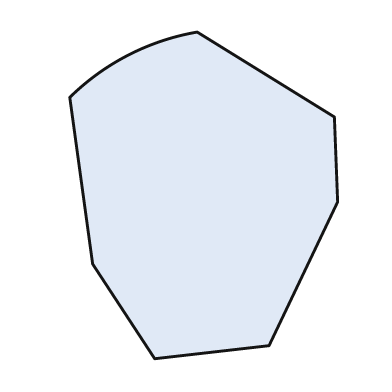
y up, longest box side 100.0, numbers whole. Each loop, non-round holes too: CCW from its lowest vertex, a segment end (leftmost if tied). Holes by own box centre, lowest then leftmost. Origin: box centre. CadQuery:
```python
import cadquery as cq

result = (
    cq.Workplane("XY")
    .moveTo(-15.0, -50.0)
    .lineTo(20.0, -46.0)
    .lineTo(41.0, -2.0)
    .lineTo(40.0, 24.0)
    .lineTo(-2.0, 50.0)
    .threePointArc((-23.0, 43.0), (-41.0, 30.0))
    .lineTo(-34.0, -21.0)
    .close()
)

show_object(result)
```